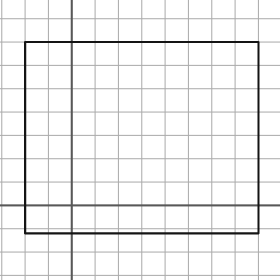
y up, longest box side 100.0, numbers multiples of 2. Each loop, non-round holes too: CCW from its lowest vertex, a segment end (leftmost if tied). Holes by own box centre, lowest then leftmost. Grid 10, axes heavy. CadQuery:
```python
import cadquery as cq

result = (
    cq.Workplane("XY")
    .moveTo(-20.0, -12.0)
    .lineTo(80.0, -12.0)
    .lineTo(80.0, 70.0)
    .lineTo(-20.0, 70.0)
    .close()
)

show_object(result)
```